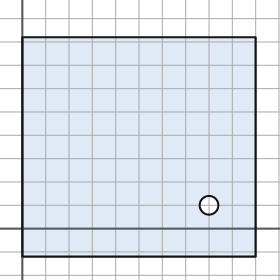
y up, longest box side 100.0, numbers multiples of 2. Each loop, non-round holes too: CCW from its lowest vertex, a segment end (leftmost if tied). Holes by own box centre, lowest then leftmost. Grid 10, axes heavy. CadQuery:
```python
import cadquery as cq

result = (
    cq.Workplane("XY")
    .moveTo(0.0, -12.0)
    .lineTo(100.0, -12.0)
    .lineTo(100.0, 82.0)
    .lineTo(0.0, 82.0)
    .close()
    .moveTo(80.0, 10.0)
    .circle(4.0)
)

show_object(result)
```